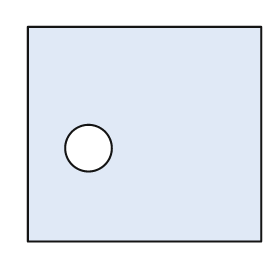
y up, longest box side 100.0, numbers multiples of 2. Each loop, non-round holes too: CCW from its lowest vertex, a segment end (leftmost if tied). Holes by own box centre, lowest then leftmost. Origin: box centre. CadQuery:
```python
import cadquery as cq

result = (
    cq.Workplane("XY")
    .moveTo(-50.0, -46.0)
    .lineTo(50.0, -46.0)
    .lineTo(50.0, 46.0)
    .lineTo(-50.0, 46.0)
    .close()
    .moveTo(-24.0, -6.0)
    .circle(10.0)
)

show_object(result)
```